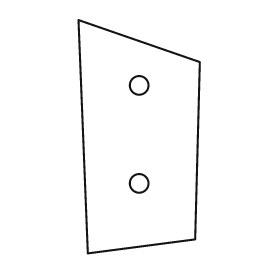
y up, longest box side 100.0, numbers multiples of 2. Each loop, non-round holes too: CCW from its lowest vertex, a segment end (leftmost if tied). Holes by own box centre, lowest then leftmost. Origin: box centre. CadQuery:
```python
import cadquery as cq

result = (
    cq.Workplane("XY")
    .moveTo(-22.0, -50.0)
    .lineTo(24.0, -44.0)
    .lineTo(26.0, 32.0)
    .lineTo(-26.0, 50.0)
    .close()
    .moveTo(0.0, -20.0)
    .circle(4.0)
    .moveTo(0.0, 22.0)
    .circle(4.0)
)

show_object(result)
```